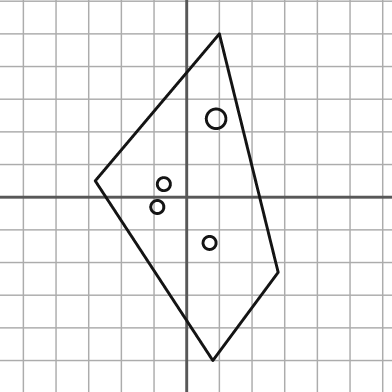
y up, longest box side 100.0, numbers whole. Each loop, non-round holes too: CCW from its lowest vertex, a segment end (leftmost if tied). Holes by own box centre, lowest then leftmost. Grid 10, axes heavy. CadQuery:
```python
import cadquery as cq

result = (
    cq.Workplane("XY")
    .moveTo(8.0, -50.0)
    .lineTo(28.0, -23.0)
    .lineTo(10.0, 50.0)
    .lineTo(-28.0, 5.0)
    .close()
    .moveTo(7.0, -14.0)
    .circle(2.0)
    .moveTo(-9.0, -3.0)
    .circle(2.0)
    .moveTo(-7.0, 4.0)
    .circle(2.0)
    .moveTo(9.0, 24.0)
    .circle(3.0)
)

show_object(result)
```